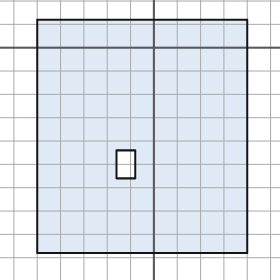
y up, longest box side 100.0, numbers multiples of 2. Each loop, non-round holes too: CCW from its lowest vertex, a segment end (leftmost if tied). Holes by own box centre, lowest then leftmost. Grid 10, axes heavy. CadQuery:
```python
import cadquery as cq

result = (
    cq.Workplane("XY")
    .moveTo(-50.0, -88.0)
    .lineTo(40.0, -88.0)
    .lineTo(40.0, 12.0)
    .lineTo(-50.0, 12.0)
    .close()
    .moveTo(-16.0, -56.0)
    .lineTo(-8.0, -56.0)
    .lineTo(-8.0, -44.0)
    .lineTo(-16.0, -44.0)
    .close()
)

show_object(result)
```